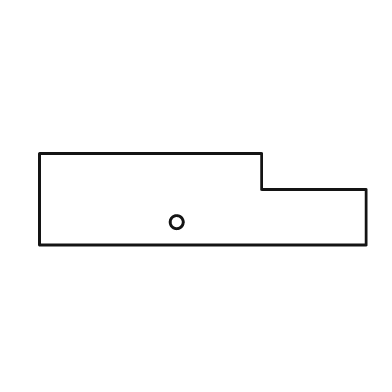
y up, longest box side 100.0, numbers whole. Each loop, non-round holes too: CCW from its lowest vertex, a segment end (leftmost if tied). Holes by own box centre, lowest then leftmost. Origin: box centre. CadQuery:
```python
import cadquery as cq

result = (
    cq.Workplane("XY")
    .moveTo(-50.0, -14.0)
    .lineTo(50.0, -14.0)
    .lineTo(50.0, 3.0)
    .lineTo(18.0, 3.0)
    .lineTo(18.0, 14.0)
    .lineTo(-50.0, 14.0)
    .close()
    .moveTo(-8.0, -7.0)
    .circle(2.0)
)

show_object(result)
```